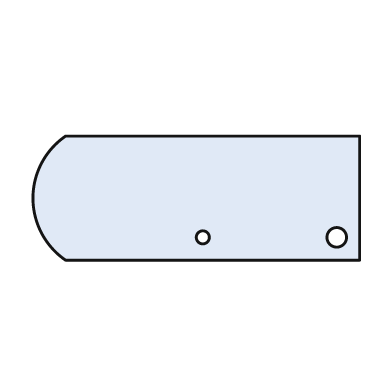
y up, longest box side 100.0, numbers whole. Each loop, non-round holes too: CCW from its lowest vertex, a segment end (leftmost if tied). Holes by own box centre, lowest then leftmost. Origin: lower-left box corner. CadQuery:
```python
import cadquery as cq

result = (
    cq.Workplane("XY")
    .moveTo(10.0, 0.0)
    .lineTo(100.0, 0.0)
    .lineTo(100.0, 38.0)
    .lineTo(10.0, 38.0)
    .threePointArc((0.0, 19.0), (10.0, 0.0))
    .close()
    .moveTo(52.0, 7.0)
    .circle(2.0)
    .moveTo(93.0, 7.0)
    .circle(3.0)
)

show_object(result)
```